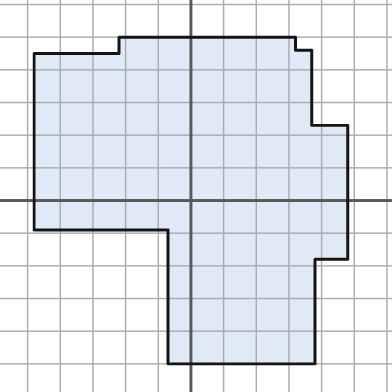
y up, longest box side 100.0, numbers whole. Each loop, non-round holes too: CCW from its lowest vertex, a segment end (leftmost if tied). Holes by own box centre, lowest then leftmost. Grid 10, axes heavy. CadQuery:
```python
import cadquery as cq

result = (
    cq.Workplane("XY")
    .moveTo(-7.0, -50.0)
    .lineTo(38.0, -50.0)
    .lineTo(38.0, -18.0)
    .lineTo(48.0, -18.0)
    .lineTo(48.0, 23.0)
    .lineTo(37.0, 23.0)
    .lineTo(37.0, 46.0)
    .lineTo(32.0, 46.0)
    .lineTo(32.0, 50.0)
    .lineTo(-22.0, 50.0)
    .lineTo(-22.0, 45.0)
    .lineTo(-48.0, 45.0)
    .lineTo(-48.0, -9.0)
    .lineTo(-7.0, -9.0)
    .close()
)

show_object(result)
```